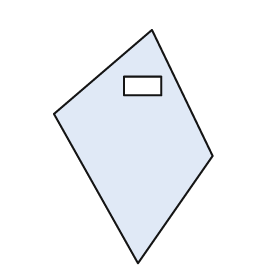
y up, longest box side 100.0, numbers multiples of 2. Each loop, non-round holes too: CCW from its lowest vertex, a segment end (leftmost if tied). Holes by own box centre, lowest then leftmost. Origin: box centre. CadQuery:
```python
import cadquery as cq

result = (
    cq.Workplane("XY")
    .moveTo(2.0, -50.0)
    .lineTo(34.0, -4.0)
    .lineTo(8.0, 50.0)
    .lineTo(-34.0, 14.0)
    .close()
    .moveTo(-4.0, 22.0)
    .lineTo(12.0, 22.0)
    .lineTo(12.0, 30.0)
    .lineTo(-4.0, 30.0)
    .close()
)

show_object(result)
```